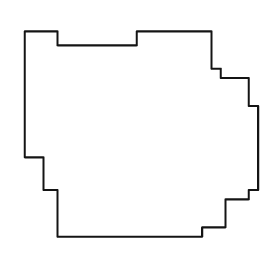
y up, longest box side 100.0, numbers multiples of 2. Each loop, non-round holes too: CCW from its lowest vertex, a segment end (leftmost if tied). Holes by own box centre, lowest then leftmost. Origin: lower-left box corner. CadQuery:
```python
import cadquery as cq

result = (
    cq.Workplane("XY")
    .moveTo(14.0, 0.0)
    .lineTo(76.0, 0.0)
    .lineTo(76.0, 4.0)
    .lineTo(86.0, 4.0)
    .lineTo(86.0, 16.0)
    .lineTo(96.0, 16.0)
    .lineTo(96.0, 20.0)
    .lineTo(100.0, 20.0)
    .lineTo(100.0, 56.0)
    .lineTo(96.0, 56.0)
    .lineTo(96.0, 68.0)
    .lineTo(84.0, 68.0)
    .lineTo(84.0, 72.0)
    .lineTo(80.0, 72.0)
    .lineTo(80.0, 88.0)
    .lineTo(48.0, 88.0)
    .lineTo(48.0, 82.0)
    .lineTo(14.0, 82.0)
    .lineTo(14.0, 88.0)
    .lineTo(0.0, 88.0)
    .lineTo(0.0, 34.0)
    .lineTo(8.0, 34.0)
    .lineTo(8.0, 20.0)
    .lineTo(14.0, 20.0)
    .close()
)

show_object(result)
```